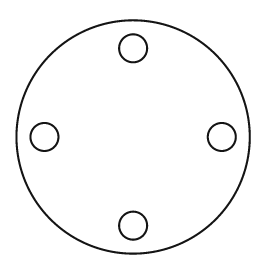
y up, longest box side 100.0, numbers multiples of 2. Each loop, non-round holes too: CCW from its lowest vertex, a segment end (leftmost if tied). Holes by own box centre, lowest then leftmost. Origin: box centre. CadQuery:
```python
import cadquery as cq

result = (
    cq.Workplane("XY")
    .moveTo(0.0, 0.0)
    .circle(50.0)
    .moveTo(0.0, -38.0)
    .circle(6.0)
    .moveTo(-38.0, 0.0)
    .circle(6.0)
    .moveTo(38.0, 0.0)
    .circle(6.0)
    .moveTo(0.0, 38.0)
    .circle(6.0)
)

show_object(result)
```